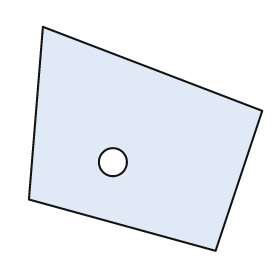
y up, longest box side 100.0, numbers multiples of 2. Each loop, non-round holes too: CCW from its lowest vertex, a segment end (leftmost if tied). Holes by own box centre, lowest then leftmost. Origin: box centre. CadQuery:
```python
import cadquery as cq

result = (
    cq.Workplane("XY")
    .moveTo(30.0, -48.0)
    .lineTo(50.0, 12.0)
    .lineTo(-44.0, 48.0)
    .lineTo(-50.0, -26.0)
    .close()
    .moveTo(-14.0, -10.0)
    .circle(6.0)
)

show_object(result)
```